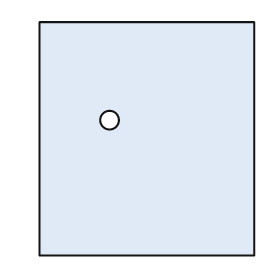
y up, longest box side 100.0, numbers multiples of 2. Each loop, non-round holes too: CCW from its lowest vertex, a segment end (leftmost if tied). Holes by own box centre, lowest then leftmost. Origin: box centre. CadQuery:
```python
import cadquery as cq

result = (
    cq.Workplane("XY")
    .moveTo(-46.0, -50.0)
    .lineTo(46.0, -50.0)
    .lineTo(46.0, 50.0)
    .lineTo(-46.0, 50.0)
    .close()
    .moveTo(-16.0, 8.0)
    .circle(4.0)
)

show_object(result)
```